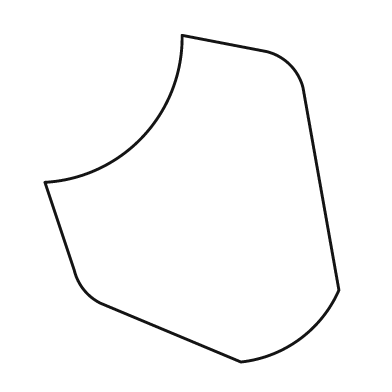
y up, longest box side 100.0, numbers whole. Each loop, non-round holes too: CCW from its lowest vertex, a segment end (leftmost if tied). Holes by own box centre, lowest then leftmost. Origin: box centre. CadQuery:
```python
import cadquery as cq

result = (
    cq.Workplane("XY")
    .moveTo(15.0, -50.0)
    .threePointArc((33.0, -43.0), (45.0, -28.0))
    .lineTo(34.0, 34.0)
    .threePointArc((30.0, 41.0), (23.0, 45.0))
    .lineTo(-3.0, 50.0)
    .threePointArc((-15.0, 19.0), (-45.0, 5.0))
    .lineTo(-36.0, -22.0)
    .threePointArc((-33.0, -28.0), (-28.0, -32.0))
    .close()
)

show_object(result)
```